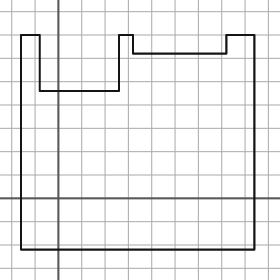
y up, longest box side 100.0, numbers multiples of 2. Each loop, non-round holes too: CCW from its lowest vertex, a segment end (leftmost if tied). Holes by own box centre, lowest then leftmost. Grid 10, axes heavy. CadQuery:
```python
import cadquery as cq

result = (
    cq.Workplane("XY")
    .moveTo(-16.0, -22.0)
    .lineTo(84.0, -22.0)
    .lineTo(84.0, 70.0)
    .lineTo(72.0, 70.0)
    .lineTo(72.0, 62.0)
    .lineTo(32.0, 62.0)
    .lineTo(32.0, 70.0)
    .lineTo(26.0, 70.0)
    .lineTo(26.0, 46.0)
    .lineTo(-8.0, 46.0)
    .lineTo(-8.0, 70.0)
    .lineTo(-16.0, 70.0)
    .close()
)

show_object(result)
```